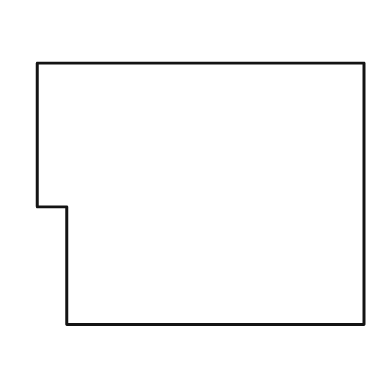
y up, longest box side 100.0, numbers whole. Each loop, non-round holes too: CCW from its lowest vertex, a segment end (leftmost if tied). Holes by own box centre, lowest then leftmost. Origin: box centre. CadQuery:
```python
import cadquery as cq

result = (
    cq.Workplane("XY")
    .moveTo(-41.0, -40.0)
    .lineTo(50.0, -40.0)
    .lineTo(50.0, 40.0)
    .lineTo(-50.0, 40.0)
    .lineTo(-50.0, -4.0)
    .lineTo(-41.0, -4.0)
    .close()
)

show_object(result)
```